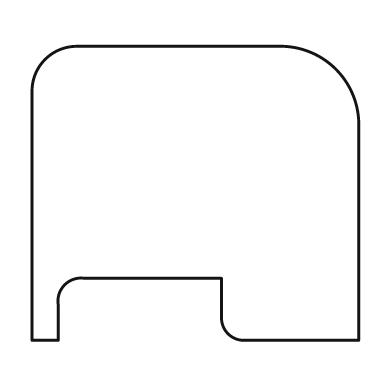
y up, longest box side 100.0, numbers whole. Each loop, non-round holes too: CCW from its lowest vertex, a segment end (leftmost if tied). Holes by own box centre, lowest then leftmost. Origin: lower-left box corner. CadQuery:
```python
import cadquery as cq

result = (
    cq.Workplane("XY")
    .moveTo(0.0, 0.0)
    .lineTo(8.0, 0.0)
    .lineTo(8.0, 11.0)
    .threePointArc((10.0, 17.0), (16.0, 19.0))
    .lineTo(58.0, 19.0)
    .lineTo(58.0, 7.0)
    .threePointArc((60.0, 2.0), (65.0, 0.0))
    .lineTo(100.0, 0.0)
    .lineTo(100.0, 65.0)
    .threePointArc((93.0, 83.0), (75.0, 90.0))
    .lineTo(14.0, 90.0)
    .threePointArc((4.0, 86.0), (0.0, 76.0))
    .close()
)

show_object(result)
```